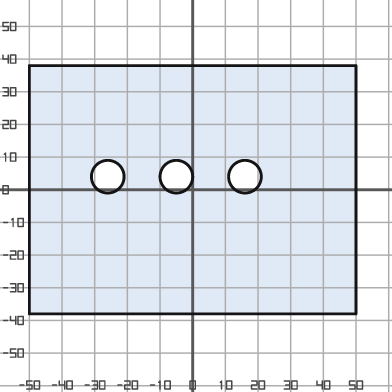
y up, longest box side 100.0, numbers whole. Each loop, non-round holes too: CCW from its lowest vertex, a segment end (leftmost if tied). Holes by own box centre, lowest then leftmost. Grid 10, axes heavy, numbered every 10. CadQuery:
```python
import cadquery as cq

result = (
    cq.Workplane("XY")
    .moveTo(-50.0, -38.0)
    .lineTo(50.0, -38.0)
    .lineTo(50.0, 38.0)
    .lineTo(-50.0, 38.0)
    .close()
    .moveTo(-26.0, 4.0)
    .circle(5.0)
    .moveTo(-5.0, 4.0)
    .circle(5.0)
    .moveTo(16.0, 4.0)
    .circle(5.0)
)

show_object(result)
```